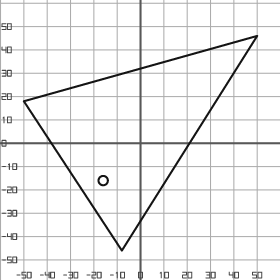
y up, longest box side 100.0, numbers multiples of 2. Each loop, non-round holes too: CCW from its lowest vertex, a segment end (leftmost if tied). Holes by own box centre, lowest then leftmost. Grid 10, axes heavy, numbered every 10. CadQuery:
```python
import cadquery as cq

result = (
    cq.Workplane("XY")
    .moveTo(-8.0, -46.0)
    .lineTo(50.0, 46.0)
    .lineTo(-50.0, 18.0)
    .close()
    .moveTo(-16.0, -16.0)
    .circle(2.0)
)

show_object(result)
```